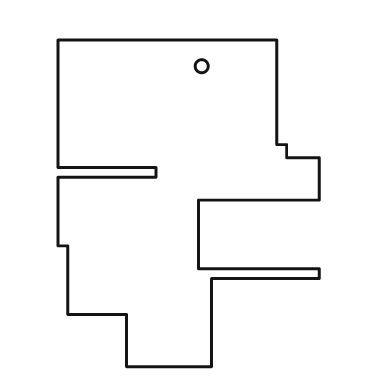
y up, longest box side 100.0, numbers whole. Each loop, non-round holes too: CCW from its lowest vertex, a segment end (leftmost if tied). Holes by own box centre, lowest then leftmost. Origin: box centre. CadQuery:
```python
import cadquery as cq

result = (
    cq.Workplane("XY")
    .moveTo(-19.0, -50.0)
    .lineTo(7.0, -50.0)
    .lineTo(7.0, -23.0)
    .lineTo(40.0, -23.0)
    .lineTo(40.0, -20.0)
    .lineTo(3.0, -20.0)
    .lineTo(3.0, 1.0)
    .lineTo(40.0, 1.0)
    .lineTo(40.0, 14.0)
    .lineTo(30.0, 14.0)
    .lineTo(30.0, 18.0)
    .lineTo(27.0, 18.0)
    .lineTo(27.0, 50.0)
    .lineTo(-40.0, 50.0)
    .lineTo(-40.0, 11.0)
    .lineTo(-10.0, 11.0)
    .lineTo(-10.0, 8.0)
    .lineTo(-40.0, 8.0)
    .lineTo(-40.0, -13.0)
    .lineTo(-37.0, -13.0)
    .lineTo(-37.0, -34.0)
    .lineTo(-19.0, -34.0)
    .close()
    .moveTo(4.0, 42.0)
    .circle(2.0)
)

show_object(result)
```